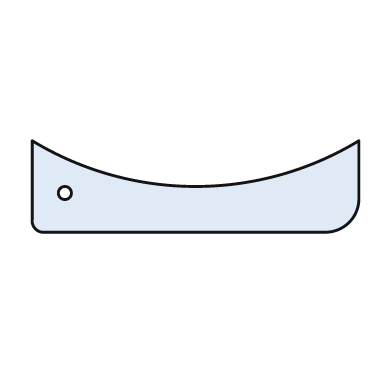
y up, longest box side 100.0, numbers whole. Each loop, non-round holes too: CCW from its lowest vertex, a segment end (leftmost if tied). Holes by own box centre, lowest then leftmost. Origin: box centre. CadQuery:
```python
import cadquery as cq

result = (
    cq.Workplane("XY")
    .moveTo(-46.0, -14.0)
    .lineTo(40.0, -14.0)
    .threePointArc((47.0, -11.0), (50.0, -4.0))
    .lineTo(50.0, 14.0)
    .threePointArc((0.0, 0.0), (-50.0, 14.0))
    .lineTo(-50.0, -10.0)
    .threePointArc((-49.0, -13.0), (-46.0, -14.0))
    .close()
    .moveTo(-40.0, -2.0)
    .circle(2.0)
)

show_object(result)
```